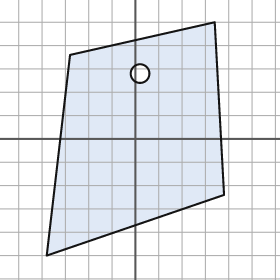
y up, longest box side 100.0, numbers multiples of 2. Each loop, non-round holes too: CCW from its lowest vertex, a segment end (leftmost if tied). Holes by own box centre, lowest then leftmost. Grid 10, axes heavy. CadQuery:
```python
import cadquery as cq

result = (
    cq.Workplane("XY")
    .moveTo(-38.0, -50.0)
    .lineTo(38.0, -24.0)
    .lineTo(34.0, 50.0)
    .lineTo(-28.0, 36.0)
    .close()
    .moveTo(2.0, 28.0)
    .circle(4.0)
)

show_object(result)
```